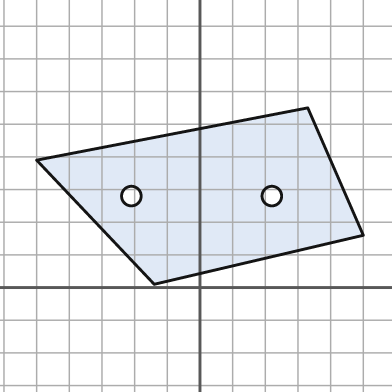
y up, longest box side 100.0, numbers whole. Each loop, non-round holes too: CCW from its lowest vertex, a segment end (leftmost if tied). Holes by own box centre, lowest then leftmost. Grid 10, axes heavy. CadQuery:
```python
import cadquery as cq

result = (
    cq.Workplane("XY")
    .moveTo(-14.0, 1.0)
    .lineTo(50.0, 16.0)
    .lineTo(33.0, 55.0)
    .lineTo(-50.0, 39.0)
    .close()
    .moveTo(-21.0, 28.0)
    .circle(3.0)
    .moveTo(22.0, 28.0)
    .circle(3.0)
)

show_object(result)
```